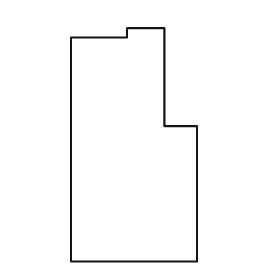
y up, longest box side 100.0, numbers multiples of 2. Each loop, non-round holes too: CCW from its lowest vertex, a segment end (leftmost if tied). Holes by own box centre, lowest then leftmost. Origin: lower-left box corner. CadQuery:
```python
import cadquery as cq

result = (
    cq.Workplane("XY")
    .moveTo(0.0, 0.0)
    .lineTo(54.0, 0.0)
    .lineTo(54.0, 58.0)
    .lineTo(40.0, 58.0)
    .lineTo(40.0, 100.0)
    .lineTo(24.0, 100.0)
    .lineTo(24.0, 96.0)
    .lineTo(0.0, 96.0)
    .close()
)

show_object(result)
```